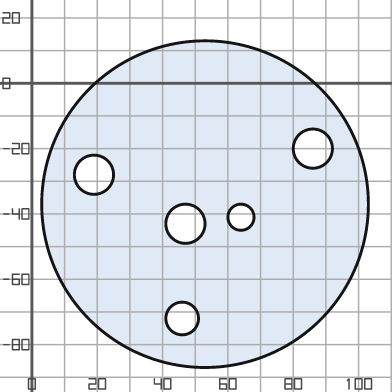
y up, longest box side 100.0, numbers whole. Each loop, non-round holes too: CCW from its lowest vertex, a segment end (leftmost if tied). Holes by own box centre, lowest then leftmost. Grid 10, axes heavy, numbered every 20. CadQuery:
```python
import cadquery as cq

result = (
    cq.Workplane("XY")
    .moveTo(53.0, -37.0)
    .circle(50.0)
    .moveTo(46.0, -72.0)
    .circle(5.0)
    .moveTo(47.0, -43.0)
    .circle(6.0)
    .moveTo(64.0, -41.0)
    .circle(4.0)
    .moveTo(19.0, -28.0)
    .circle(6.0)
    .moveTo(86.0, -20.0)
    .circle(6.0)
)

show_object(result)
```